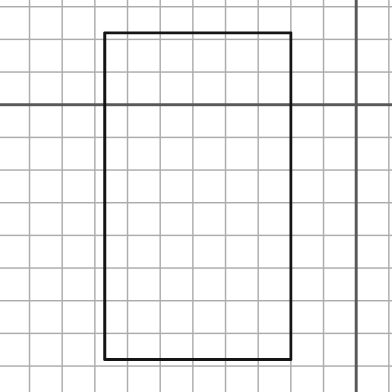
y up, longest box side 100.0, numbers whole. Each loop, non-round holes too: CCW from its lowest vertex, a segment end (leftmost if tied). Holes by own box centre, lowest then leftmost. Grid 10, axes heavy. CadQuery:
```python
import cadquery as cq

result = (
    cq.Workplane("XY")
    .moveTo(-77.0, -78.0)
    .lineTo(-20.0, -78.0)
    .lineTo(-20.0, 22.0)
    .lineTo(-77.0, 22.0)
    .close()
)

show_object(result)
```